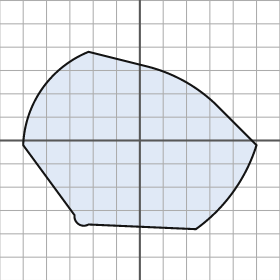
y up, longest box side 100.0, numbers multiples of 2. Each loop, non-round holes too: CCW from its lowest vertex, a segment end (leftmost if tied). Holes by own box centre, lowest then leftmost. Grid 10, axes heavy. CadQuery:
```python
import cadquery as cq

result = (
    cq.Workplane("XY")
    .moveTo(24.0, -38.0)
    .threePointArc((40.0, -22.0), (50.0, -2.0))
    .lineTo(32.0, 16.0)
    .threePointArc((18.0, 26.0), (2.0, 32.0))
    .lineTo(-22.0, 38.0)
    .threePointArc((-42.0, 22.0), (-50.0, -2.0))
    .lineTo(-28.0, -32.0)
    .threePointArc((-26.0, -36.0), (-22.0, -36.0))
    .close()
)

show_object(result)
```